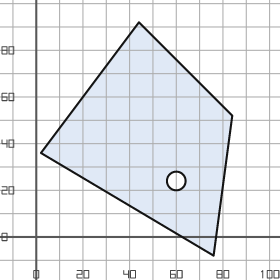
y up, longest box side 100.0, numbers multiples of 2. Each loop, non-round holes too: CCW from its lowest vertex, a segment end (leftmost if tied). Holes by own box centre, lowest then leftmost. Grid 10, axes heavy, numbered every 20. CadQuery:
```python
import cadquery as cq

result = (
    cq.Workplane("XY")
    .moveTo(76.0, -8.0)
    .lineTo(84.0, 52.0)
    .lineTo(44.0, 92.0)
    .lineTo(2.0, 36.0)
    .close()
    .moveTo(60.0, 24.0)
    .circle(4.0)
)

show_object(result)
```